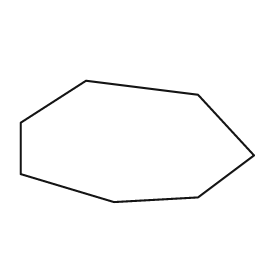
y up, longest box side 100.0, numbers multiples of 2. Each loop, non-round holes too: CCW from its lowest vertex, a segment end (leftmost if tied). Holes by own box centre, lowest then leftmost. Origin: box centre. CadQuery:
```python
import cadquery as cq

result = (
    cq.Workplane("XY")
    .moveTo(-10.0, -26.0)
    .lineTo(26.0, -24.0)
    .lineTo(50.0, -6.0)
    .lineTo(26.0, 20.0)
    .lineTo(-22.0, 26.0)
    .lineTo(-50.0, 8.0)
    .lineTo(-50.0, -14.0)
    .close()
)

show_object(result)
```